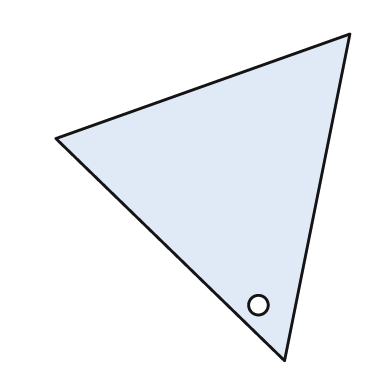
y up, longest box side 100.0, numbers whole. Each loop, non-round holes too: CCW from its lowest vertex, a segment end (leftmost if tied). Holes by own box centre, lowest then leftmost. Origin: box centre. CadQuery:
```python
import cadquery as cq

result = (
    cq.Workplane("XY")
    .moveTo(25.0, -50.0)
    .lineTo(45.0, 50.0)
    .lineTo(-45.0, 18.0)
    .close()
    .moveTo(17.0, -33.0)
    .circle(3.0)
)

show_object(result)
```